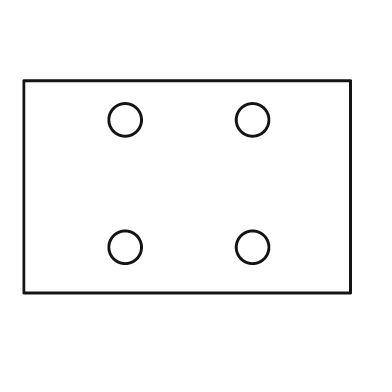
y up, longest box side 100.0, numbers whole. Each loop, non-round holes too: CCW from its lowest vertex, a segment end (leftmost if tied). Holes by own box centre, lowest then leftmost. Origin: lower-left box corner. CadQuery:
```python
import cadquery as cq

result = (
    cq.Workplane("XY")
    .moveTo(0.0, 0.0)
    .lineTo(100.0, 0.0)
    .lineTo(100.0, 65.0)
    .lineTo(0.0, 65.0)
    .close()
    .moveTo(31.0, 14.0)
    .circle(5.0)
    .moveTo(70.0, 14.0)
    .circle(5.0)
    .moveTo(31.0, 53.0)
    .circle(5.0)
    .moveTo(70.0, 53.0)
    .circle(5.0)
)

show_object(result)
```